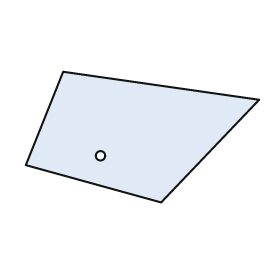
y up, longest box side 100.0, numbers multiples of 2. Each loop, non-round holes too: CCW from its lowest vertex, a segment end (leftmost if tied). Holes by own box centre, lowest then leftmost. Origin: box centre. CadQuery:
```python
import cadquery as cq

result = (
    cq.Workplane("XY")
    .moveTo(8.0, -28.0)
    .lineTo(50.0, 16.0)
    .lineTo(-34.0, 28.0)
    .lineTo(-50.0, -12.0)
    .close()
    .moveTo(-18.0, -8.0)
    .circle(2.0)
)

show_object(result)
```